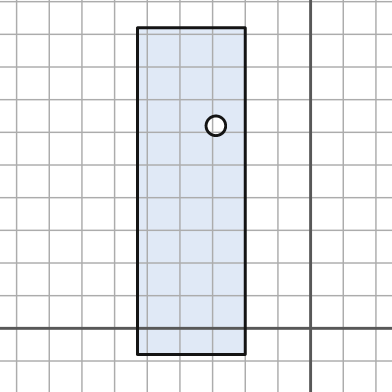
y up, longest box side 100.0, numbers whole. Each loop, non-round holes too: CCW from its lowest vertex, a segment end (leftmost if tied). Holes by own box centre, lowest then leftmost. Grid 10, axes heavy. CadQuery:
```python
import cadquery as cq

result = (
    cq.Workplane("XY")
    .moveTo(-53.0, -8.0)
    .lineTo(-20.0, -8.0)
    .lineTo(-20.0, 92.0)
    .lineTo(-53.0, 92.0)
    .close()
    .moveTo(-29.0, 62.0)
    .circle(3.0)
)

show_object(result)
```